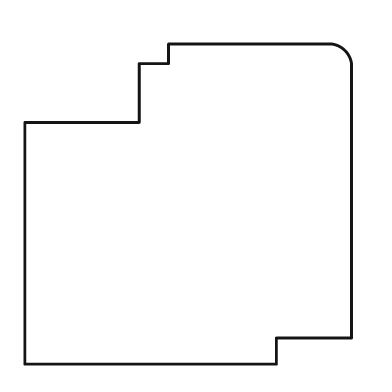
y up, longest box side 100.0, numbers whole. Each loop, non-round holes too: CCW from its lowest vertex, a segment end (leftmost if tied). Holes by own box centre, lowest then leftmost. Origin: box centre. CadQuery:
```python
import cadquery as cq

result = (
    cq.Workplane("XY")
    .moveTo(-50.0, -49.0)
    .lineTo(27.0, -49.0)
    .lineTo(27.0, -41.0)
    .lineTo(50.0, -41.0)
    .lineTo(50.0, 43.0)
    .threePointArc((48.0, 47.0), (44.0, 49.0))
    .lineTo(-6.0, 49.0)
    .lineTo(-6.0, 43.0)
    .lineTo(-15.0, 43.0)
    .lineTo(-15.0, 25.0)
    .lineTo(-50.0, 25.0)
    .close()
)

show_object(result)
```